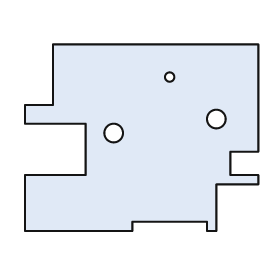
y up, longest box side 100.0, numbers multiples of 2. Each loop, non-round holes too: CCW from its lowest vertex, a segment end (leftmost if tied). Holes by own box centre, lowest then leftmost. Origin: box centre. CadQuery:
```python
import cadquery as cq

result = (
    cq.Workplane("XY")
    .moveTo(-50.0, -40.0)
    .lineTo(-4.0, -40.0)
    .lineTo(-4.0, -36.0)
    .lineTo(28.0, -36.0)
    .lineTo(28.0, -40.0)
    .lineTo(32.0, -40.0)
    .lineTo(32.0, -20.0)
    .lineTo(50.0, -20.0)
    .lineTo(50.0, -16.0)
    .lineTo(38.0, -16.0)
    .lineTo(38.0, -6.0)
    .lineTo(50.0, -6.0)
    .lineTo(50.0, 40.0)
    .lineTo(-38.0, 40.0)
    .lineTo(-38.0, 14.0)
    .lineTo(-50.0, 14.0)
    .lineTo(-50.0, 6.0)
    .lineTo(-24.0, 6.0)
    .lineTo(-24.0, -16.0)
    .lineTo(-50.0, -16.0)
    .close()
    .moveTo(-12.0, 2.0)
    .circle(4.0)
    .moveTo(32.0, 8.0)
    .circle(4.0)
    .moveTo(12.0, 26.0)
    .circle(2.0)
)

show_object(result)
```